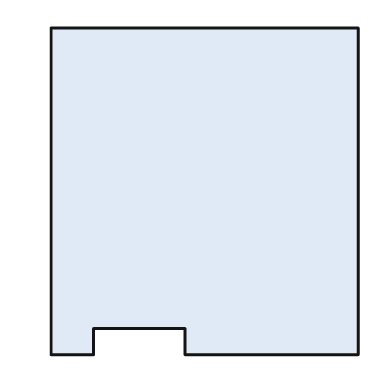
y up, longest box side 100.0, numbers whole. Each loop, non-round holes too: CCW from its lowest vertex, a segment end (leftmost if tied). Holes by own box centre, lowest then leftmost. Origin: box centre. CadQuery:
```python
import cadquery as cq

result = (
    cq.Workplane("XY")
    .moveTo(-47.0, -50.0)
    .lineTo(-34.0, -50.0)
    .lineTo(-34.0, -42.0)
    .lineTo(-6.0, -42.0)
    .lineTo(-6.0, -50.0)
    .lineTo(47.0, -50.0)
    .lineTo(47.0, 50.0)
    .lineTo(-47.0, 50.0)
    .close()
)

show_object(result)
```